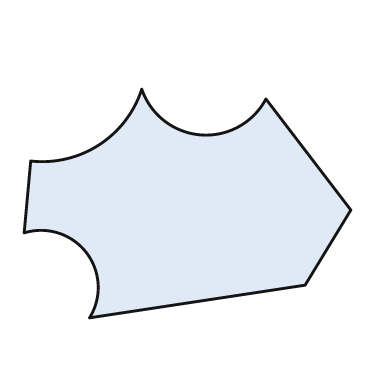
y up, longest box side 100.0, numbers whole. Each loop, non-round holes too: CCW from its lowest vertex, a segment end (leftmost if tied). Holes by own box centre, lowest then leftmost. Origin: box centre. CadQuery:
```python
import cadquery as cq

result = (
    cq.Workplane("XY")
    .moveTo(-30.0, -35.0)
    .lineTo(36.0, -25.0)
    .lineTo(50.0, -2.0)
    .lineTo(24.0, 32.0)
    .threePointArc((4.0, 21.0), (-14.0, 35.0))
    .threePointArc((-27.0, 18.0), (-48.0, 13.0))
    .lineTo(-50.0, -9.0)
    .threePointArc((-31.0, -15.0), (-30.0, -35.0))
    .close()
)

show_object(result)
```